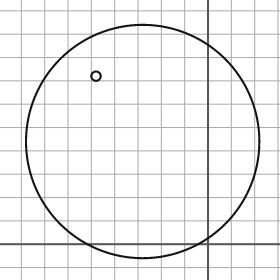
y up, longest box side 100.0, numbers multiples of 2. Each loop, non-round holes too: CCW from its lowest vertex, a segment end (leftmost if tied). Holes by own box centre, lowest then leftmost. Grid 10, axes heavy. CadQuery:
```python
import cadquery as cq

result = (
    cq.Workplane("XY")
    .moveTo(-28.0, 44.0)
    .circle(50.0)
    .moveTo(-48.0, 72.0)
    .circle(2.0)
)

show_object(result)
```